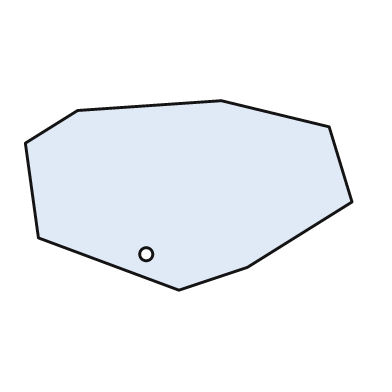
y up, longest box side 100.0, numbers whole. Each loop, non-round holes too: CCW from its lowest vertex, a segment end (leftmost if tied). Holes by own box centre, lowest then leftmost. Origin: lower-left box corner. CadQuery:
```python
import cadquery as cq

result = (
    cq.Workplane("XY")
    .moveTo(47.0, 0.0)
    .lineTo(68.0, 7.0)
    .lineTo(100.0, 27.0)
    .lineTo(93.0, 50.0)
    .lineTo(60.0, 58.0)
    .lineTo(16.0, 55.0)
    .lineTo(0.0, 45.0)
    .lineTo(4.0, 16.0)
    .close()
    .moveTo(37.0, 11.0)
    .circle(2.0)
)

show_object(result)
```